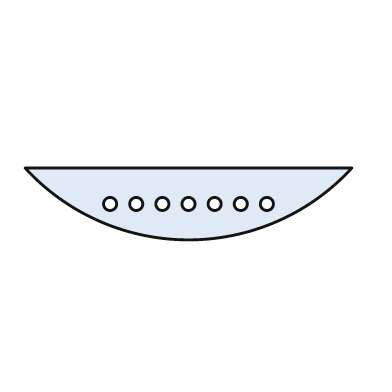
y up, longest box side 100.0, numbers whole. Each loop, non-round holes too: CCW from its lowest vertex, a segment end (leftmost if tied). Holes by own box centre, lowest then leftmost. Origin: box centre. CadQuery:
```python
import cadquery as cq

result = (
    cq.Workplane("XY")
    .moveTo(-50.0, 11.0)
    .threePointArc((0.0, -11.0), (50.0, 11.0))
    .close()
    .moveTo(-24.0, 0.0)
    .circle(2.0)
    .moveTo(-16.0, 0.0)
    .circle(2.0)
    .moveTo(-8.0, 0.0)
    .circle(2.0)
    .moveTo(0.0, 0.0)
    .circle(2.0)
    .moveTo(8.0, 0.0)
    .circle(2.0)
    .moveTo(16.0, 0.0)
    .circle(2.0)
    .moveTo(24.0, 0.0)
    .circle(2.0)
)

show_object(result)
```